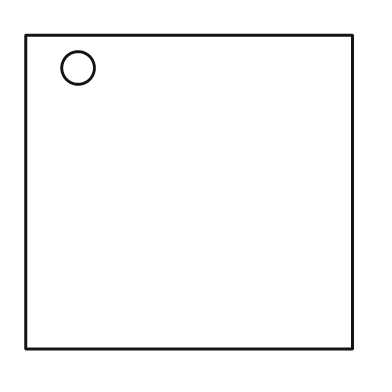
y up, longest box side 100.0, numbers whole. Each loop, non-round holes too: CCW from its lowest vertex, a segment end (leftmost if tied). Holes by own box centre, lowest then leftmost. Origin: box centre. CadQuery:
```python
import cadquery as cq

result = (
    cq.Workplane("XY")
    .moveTo(-50.0, -48.0)
    .lineTo(50.0, -48.0)
    .lineTo(50.0, 48.0)
    .lineTo(-50.0, 48.0)
    .close()
    .moveTo(-34.0, 38.0)
    .circle(5.0)
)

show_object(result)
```